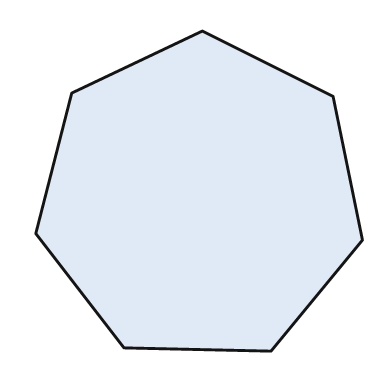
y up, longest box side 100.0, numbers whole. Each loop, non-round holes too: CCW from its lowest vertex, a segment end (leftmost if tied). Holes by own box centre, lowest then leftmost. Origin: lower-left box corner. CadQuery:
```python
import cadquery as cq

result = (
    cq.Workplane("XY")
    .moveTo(72.0, 0.0)
    .lineTo(100.0, 34.0)
    .lineTo(91.0, 78.0)
    .lineTo(51.0, 98.0)
    .lineTo(11.0, 79.0)
    .lineTo(0.0, 36.0)
    .lineTo(27.0, 1.0)
    .close()
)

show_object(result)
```